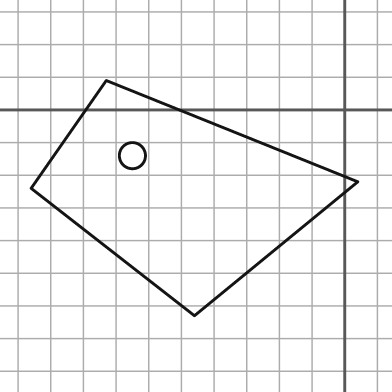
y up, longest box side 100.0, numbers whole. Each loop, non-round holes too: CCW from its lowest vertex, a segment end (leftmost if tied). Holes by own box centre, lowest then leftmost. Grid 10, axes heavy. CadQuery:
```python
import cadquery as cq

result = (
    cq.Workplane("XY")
    .moveTo(-46.0, -63.0)
    .lineTo(4.0, -22.0)
    .lineTo(-73.0, 9.0)
    .lineTo(-96.0, -24.0)
    .close()
    .moveTo(-65.0, -14.0)
    .circle(4.0)
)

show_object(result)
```